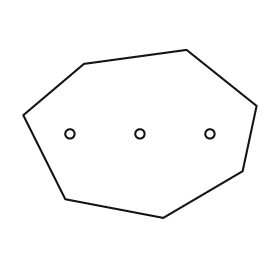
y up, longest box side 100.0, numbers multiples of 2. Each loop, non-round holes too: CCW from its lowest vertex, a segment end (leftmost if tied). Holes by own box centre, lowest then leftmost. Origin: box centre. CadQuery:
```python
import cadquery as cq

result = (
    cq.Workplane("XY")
    .moveTo(10.0, -36.0)
    .lineTo(44.0, -16.0)
    .lineTo(50.0, 12.0)
    .lineTo(20.0, 36.0)
    .lineTo(-24.0, 30.0)
    .lineTo(-50.0, 8.0)
    .lineTo(-32.0, -28.0)
    .close()
    .moveTo(-30.0, 0.0)
    .circle(2.0)
    .moveTo(0.0, 0.0)
    .circle(2.0)
    .moveTo(30.0, 0.0)
    .circle(2.0)
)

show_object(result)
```